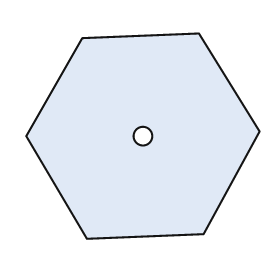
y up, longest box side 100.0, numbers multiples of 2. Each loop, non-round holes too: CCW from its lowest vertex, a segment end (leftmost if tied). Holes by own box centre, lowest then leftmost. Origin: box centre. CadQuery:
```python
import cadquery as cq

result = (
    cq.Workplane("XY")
    .moveTo(-24.0, -44.0)
    .lineTo(26.0, -42.0)
    .lineTo(50.0, 2.0)
    .lineTo(24.0, 44.0)
    .lineTo(-26.0, 42.0)
    .lineTo(-50.0, 0.0)
    .close()
    .moveTo(0.0, 0.0)
    .circle(4.0)
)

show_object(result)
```